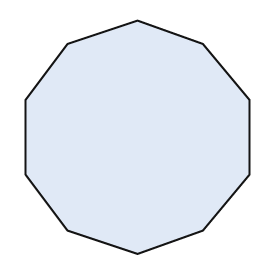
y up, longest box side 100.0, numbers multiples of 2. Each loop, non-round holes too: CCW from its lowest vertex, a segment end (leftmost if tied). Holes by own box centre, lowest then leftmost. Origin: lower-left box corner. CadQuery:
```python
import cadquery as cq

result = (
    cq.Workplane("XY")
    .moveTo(48.0, 0.0)
    .lineTo(76.0, 10.0)
    .lineTo(96.0, 34.0)
    .lineTo(96.0, 66.0)
    .lineTo(76.0, 90.0)
    .lineTo(48.0, 100.0)
    .lineTo(18.0, 90.0)
    .lineTo(0.0, 66.0)
    .lineTo(0.0, 34.0)
    .lineTo(18.0, 10.0)
    .close()
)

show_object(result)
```